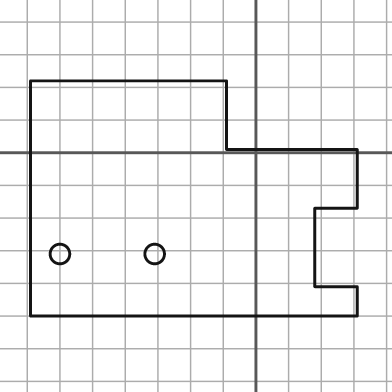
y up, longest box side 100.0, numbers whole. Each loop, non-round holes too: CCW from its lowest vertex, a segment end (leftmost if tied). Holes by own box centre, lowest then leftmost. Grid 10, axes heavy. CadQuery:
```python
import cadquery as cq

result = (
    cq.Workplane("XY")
    .moveTo(-69.0, -50.0)
    .lineTo(31.0, -50.0)
    .lineTo(31.0, -41.0)
    .lineTo(18.0, -41.0)
    .lineTo(18.0, -17.0)
    .lineTo(31.0, -17.0)
    .lineTo(31.0, 1.0)
    .lineTo(-9.0, 1.0)
    .lineTo(-9.0, 22.0)
    .lineTo(-69.0, 22.0)
    .close()
    .moveTo(-60.0, -31.0)
    .circle(3.0)
    .moveTo(-31.0, -31.0)
    .circle(3.0)
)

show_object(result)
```